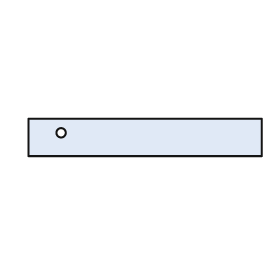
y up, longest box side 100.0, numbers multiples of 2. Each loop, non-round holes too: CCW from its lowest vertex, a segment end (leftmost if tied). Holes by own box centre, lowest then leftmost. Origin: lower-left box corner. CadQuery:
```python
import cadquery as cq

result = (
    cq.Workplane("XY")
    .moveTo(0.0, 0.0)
    .lineTo(100.0, 0.0)
    .lineTo(100.0, 16.0)
    .lineTo(0.0, 16.0)
    .close()
    .moveTo(14.0, 10.0)
    .circle(2.0)
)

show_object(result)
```